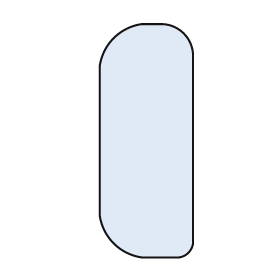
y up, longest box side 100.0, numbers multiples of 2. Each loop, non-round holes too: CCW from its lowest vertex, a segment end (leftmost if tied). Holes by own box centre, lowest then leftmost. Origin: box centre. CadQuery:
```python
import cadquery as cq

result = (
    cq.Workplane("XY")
    .moveTo(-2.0, -50.0)
    .lineTo(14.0, -50.0)
    .threePointArc((18.0, -48.0), (20.0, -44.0))
    .lineTo(20.0, 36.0)
    .threePointArc((16.0, 46.0), (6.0, 50.0))
    .lineTo(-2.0, 50.0)
    .threePointArc((-14.0, 44.0), (-20.0, 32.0))
    .lineTo(-20.0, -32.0)
    .threePointArc((-14.0, -44.0), (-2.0, -50.0))
    .close()
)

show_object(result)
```